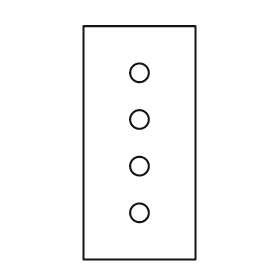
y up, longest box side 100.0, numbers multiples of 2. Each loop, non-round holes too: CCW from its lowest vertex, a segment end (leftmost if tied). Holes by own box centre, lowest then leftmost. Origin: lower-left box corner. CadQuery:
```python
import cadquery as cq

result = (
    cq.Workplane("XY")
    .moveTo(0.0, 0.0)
    .lineTo(48.0, 0.0)
    .lineTo(48.0, 100.0)
    .lineTo(0.0, 100.0)
    .close()
    .moveTo(24.0, 20.0)
    .circle(4.0)
    .moveTo(24.0, 40.0)
    .circle(4.0)
    .moveTo(24.0, 60.0)
    .circle(4.0)
    .moveTo(24.0, 80.0)
    .circle(4.0)
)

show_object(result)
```